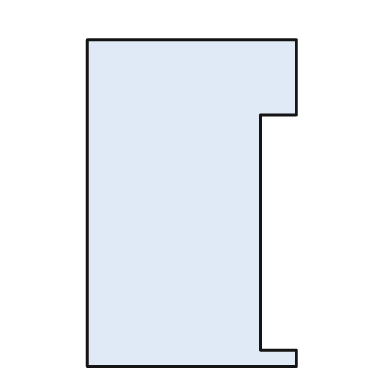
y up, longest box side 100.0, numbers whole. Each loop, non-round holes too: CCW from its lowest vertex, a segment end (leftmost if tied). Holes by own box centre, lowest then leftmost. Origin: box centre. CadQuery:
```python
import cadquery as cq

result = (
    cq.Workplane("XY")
    .moveTo(-32.0, -50.0)
    .lineTo(32.0, -50.0)
    .lineTo(32.0, -45.0)
    .lineTo(21.0, -45.0)
    .lineTo(21.0, 27.0)
    .lineTo(32.0, 27.0)
    .lineTo(32.0, 50.0)
    .lineTo(-32.0, 50.0)
    .close()
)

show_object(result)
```